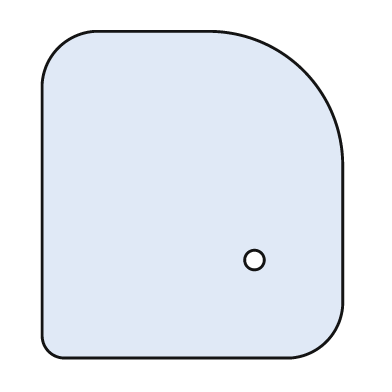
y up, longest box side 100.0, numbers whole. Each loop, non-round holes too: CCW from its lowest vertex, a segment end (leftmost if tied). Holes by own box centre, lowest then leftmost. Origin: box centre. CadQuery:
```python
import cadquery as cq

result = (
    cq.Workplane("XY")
    .moveTo(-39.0, -50.0)
    .lineTo(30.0, -50.0)
    .threePointArc((41.0, -45.0), (46.0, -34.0))
    .lineTo(46.0, 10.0)
    .threePointArc((34.0, 38.0), (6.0, 50.0))
    .lineTo(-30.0, 50.0)
    .threePointArc((-41.0, 45.0), (-46.0, 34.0))
    .lineTo(-46.0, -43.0)
    .threePointArc((-44.0, -48.0), (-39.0, -50.0))
    .close()
    .moveTo(19.0, -20.0)
    .circle(3.0)
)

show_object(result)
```